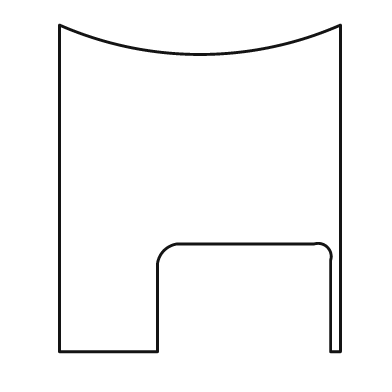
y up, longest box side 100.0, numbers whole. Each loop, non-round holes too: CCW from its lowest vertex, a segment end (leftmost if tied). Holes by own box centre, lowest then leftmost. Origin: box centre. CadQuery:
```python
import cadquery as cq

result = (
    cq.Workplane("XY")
    .moveTo(-43.0, -50.0)
    .lineTo(-13.0, -50.0)
    .lineTo(-13.0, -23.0)
    .threePointArc((-11.0, -19.0), (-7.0, -17.0))
    .lineTo(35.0, -17.0)
    .threePointArc((39.0, -18.0), (40.0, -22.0))
    .lineTo(40.0, -50.0)
    .lineTo(43.0, -50.0)
    .lineTo(43.0, 50.0)
    .threePointArc((0.0, 41.0), (-43.0, 50.0))
    .close()
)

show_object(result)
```